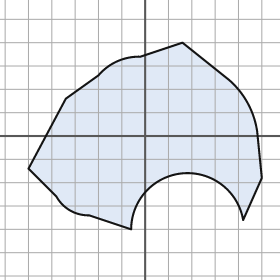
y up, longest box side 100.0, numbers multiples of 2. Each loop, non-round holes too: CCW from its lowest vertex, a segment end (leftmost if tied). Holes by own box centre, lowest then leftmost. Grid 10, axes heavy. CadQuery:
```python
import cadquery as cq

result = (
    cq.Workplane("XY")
    .moveTo(-6.0, -40.0)
    .threePointArc((16.0, -16.0), (42.0, -36.0))
    .lineTo(50.0, -18.0)
    .lineTo(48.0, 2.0)
    .threePointArc((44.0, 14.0), (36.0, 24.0))
    .lineTo(16.0, 40.0)
    .lineTo(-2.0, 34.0)
    .threePointArc((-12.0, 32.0), (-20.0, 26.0))
    .lineTo(-34.0, 16.0)
    .lineTo(-50.0, -14.0)
    .lineTo(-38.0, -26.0)
    .threePointArc((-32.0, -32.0), (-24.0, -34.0))
    .close()
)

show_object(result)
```